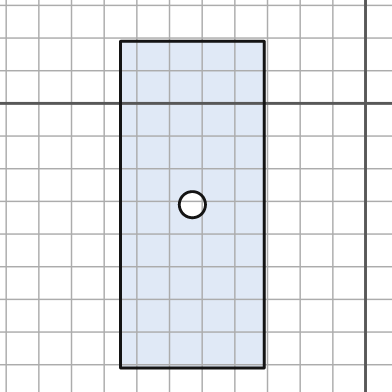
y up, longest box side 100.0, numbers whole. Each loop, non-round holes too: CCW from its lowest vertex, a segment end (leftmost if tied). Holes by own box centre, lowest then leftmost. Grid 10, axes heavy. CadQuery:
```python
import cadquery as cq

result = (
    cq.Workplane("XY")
    .moveTo(-75.0, -81.0)
    .lineTo(-31.0, -81.0)
    .lineTo(-31.0, 19.0)
    .lineTo(-75.0, 19.0)
    .close()
    .moveTo(-53.0, -31.0)
    .circle(4.0)
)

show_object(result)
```